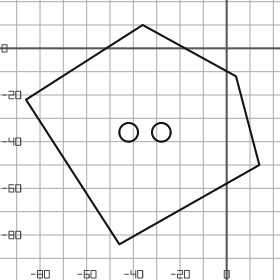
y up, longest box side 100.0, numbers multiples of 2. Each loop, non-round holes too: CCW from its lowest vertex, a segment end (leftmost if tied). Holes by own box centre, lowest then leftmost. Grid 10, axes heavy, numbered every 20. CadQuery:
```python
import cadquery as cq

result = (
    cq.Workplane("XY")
    .moveTo(-46.0, -84.0)
    .lineTo(14.0, -50.0)
    .lineTo(4.0, -12.0)
    .lineTo(-36.0, 10.0)
    .lineTo(-86.0, -22.0)
    .close()
    .moveTo(-42.0, -36.0)
    .circle(4.0)
    .moveTo(-28.0, -36.0)
    .circle(4.0)
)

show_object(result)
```